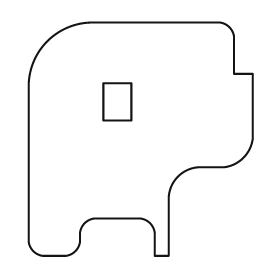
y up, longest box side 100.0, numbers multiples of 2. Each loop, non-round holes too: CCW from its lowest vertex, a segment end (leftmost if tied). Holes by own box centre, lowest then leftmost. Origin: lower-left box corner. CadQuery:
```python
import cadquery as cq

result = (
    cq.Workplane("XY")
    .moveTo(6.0, 0.0)
    .lineTo(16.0, 0.0)
    .threePointArc((20.0, 2.0), (22.0, 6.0))
    .lineTo(22.0, 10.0)
    .threePointArc((24.0, 14.0), (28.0, 16.0))
    .lineTo(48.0, 16.0)
    .threePointArc((52.0, 14.0), (54.0, 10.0))
    .lineTo(54.0, 0.0)
    .lineTo(60.0, 0.0)
    .lineTo(60.0, 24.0)
    .threePointArc((64.0, 34.0), (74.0, 38.0))
    .lineTo(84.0, 38.0)
    .threePointArc((92.0, 42.0), (96.0, 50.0))
    .lineTo(96.0, 78.0)
    .lineTo(88.0, 78.0)
    .lineTo(88.0, 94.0)
    .threePointArc((86.0, 98.0), (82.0, 100.0))
    .lineTo(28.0, 100.0)
    .threePointArc((8.0, 92.0), (0.0, 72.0))
    .lineTo(0.0, 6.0)
    .threePointArc((2.0, 2.0), (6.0, 0.0))
    .close()
    .moveTo(32.0, 58.0)
    .lineTo(44.0, 58.0)
    .lineTo(44.0, 74.0)
    .lineTo(32.0, 74.0)
    .close()
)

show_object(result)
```